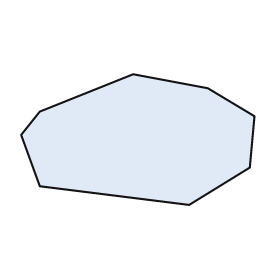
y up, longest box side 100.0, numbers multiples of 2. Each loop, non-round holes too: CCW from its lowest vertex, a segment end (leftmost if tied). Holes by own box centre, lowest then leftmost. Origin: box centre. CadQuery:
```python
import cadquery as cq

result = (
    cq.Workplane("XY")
    .moveTo(22.0, -28.0)
    .lineTo(48.0, -12.0)
    .lineTo(50.0, 10.0)
    .lineTo(30.0, 22.0)
    .lineTo(-2.0, 28.0)
    .lineTo(-42.0, 12.0)
    .lineTo(-50.0, 2.0)
    .lineTo(-42.0, -20.0)
    .close()
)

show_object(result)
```